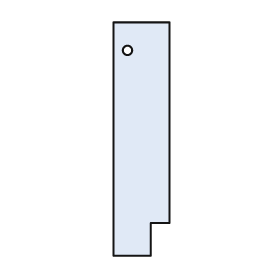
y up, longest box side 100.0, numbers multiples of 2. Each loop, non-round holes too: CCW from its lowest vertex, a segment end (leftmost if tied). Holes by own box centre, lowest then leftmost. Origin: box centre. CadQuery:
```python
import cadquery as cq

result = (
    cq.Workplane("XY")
    .moveTo(-12.0, -50.0)
    .lineTo(4.0, -50.0)
    .lineTo(4.0, -36.0)
    .lineTo(12.0, -36.0)
    .lineTo(12.0, 50.0)
    .lineTo(-12.0, 50.0)
    .close()
    .moveTo(-6.0, 38.0)
    .circle(2.0)
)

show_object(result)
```